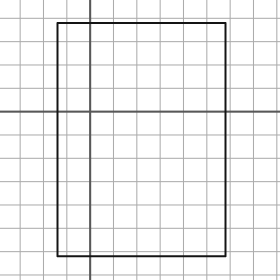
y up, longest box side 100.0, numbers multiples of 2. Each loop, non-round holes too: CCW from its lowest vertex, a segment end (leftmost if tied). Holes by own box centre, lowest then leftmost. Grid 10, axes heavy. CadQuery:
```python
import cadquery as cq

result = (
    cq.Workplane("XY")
    .moveTo(-14.0, -62.0)
    .lineTo(58.0, -62.0)
    .lineTo(58.0, 38.0)
    .lineTo(-14.0, 38.0)
    .close()
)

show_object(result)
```